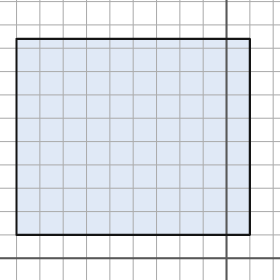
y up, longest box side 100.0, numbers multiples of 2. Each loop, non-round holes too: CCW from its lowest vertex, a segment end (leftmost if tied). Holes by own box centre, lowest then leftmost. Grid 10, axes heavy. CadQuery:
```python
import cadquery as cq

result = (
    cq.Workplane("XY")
    .moveTo(-90.0, 10.0)
    .lineTo(10.0, 10.0)
    .lineTo(10.0, 94.0)
    .lineTo(-90.0, 94.0)
    .close()
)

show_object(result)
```